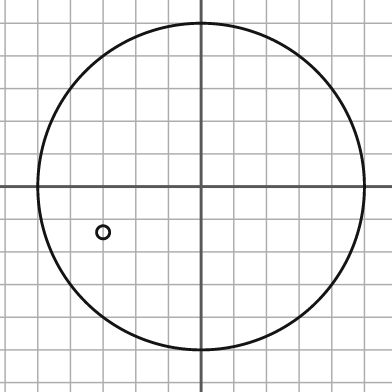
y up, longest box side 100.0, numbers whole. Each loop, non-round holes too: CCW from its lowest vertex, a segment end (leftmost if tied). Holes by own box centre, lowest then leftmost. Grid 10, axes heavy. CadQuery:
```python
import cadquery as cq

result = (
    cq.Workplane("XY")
    .moveTo(0.0, 0.0)
    .circle(50.0)
    .moveTo(-30.0, -14.0)
    .circle(2.0)
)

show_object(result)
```